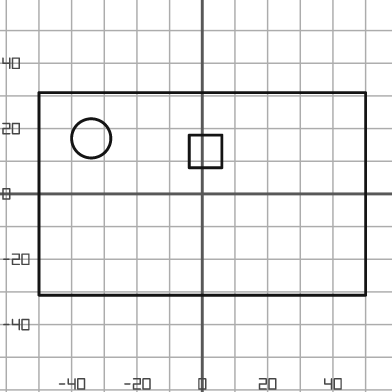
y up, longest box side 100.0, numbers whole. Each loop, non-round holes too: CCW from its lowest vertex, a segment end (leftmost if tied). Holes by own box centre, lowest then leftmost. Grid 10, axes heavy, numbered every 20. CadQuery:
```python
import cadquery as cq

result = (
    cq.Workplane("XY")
    .moveTo(-50.0, -31.0)
    .lineTo(50.0, -31.0)
    .lineTo(50.0, 31.0)
    .lineTo(-50.0, 31.0)
    .close()
    .moveTo(-4.0, 8.0)
    .lineTo(6.0, 8.0)
    .lineTo(6.0, 18.0)
    .lineTo(-4.0, 18.0)
    .close()
    .moveTo(-34.0, 17.0)
    .circle(6.0)
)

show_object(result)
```